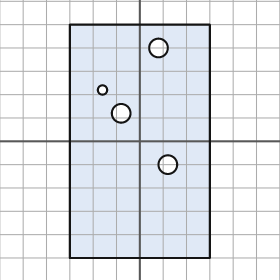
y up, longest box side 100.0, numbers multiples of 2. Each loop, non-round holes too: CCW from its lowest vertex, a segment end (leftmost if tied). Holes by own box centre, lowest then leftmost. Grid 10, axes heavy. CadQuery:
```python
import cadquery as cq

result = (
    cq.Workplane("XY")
    .moveTo(-30.0, -50.0)
    .lineTo(30.0, -50.0)
    .lineTo(30.0, 50.0)
    .lineTo(-30.0, 50.0)
    .close()
    .moveTo(12.0, -10.0)
    .circle(4.0)
    .moveTo(-8.0, 12.0)
    .circle(4.0)
    .moveTo(-16.0, 22.0)
    .circle(2.0)
    .moveTo(8.0, 40.0)
    .circle(4.0)
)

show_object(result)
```